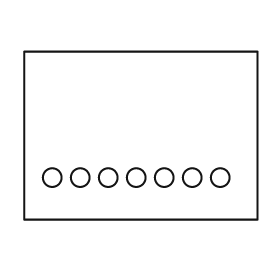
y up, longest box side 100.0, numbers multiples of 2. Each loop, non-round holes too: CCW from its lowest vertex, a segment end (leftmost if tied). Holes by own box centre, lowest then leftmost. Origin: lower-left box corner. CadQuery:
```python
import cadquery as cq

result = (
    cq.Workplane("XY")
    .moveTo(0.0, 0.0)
    .lineTo(100.0, 0.0)
    .lineTo(100.0, 72.0)
    .lineTo(0.0, 72.0)
    .close()
    .moveTo(12.0, 18.0)
    .circle(4.0)
    .moveTo(24.0, 18.0)
    .circle(4.0)
    .moveTo(36.0, 18.0)
    .circle(4.0)
    .moveTo(48.0, 18.0)
    .circle(4.0)
    .moveTo(60.0, 18.0)
    .circle(4.0)
    .moveTo(72.0, 18.0)
    .circle(4.0)
    .moveTo(84.0, 18.0)
    .circle(4.0)
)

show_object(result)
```